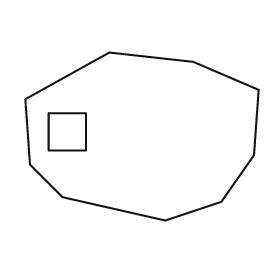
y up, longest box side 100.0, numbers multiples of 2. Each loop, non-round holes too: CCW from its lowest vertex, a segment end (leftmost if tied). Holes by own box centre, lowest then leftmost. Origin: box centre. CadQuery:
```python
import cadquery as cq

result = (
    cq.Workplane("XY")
    .moveTo(10.0, -36.0)
    .lineTo(34.0, -28.0)
    .lineTo(48.0, -8.0)
    .lineTo(50.0, 20.0)
    .lineTo(22.0, 32.0)
    .lineTo(-14.0, 36.0)
    .lineTo(-50.0, 16.0)
    .lineTo(-48.0, -12.0)
    .lineTo(-34.0, -26.0)
    .close()
    .moveTo(-40.0, -6.0)
    .lineTo(-24.0, -6.0)
    .lineTo(-24.0, 10.0)
    .lineTo(-40.0, 10.0)
    .close()
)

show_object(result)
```